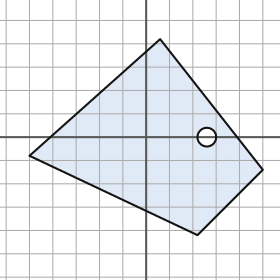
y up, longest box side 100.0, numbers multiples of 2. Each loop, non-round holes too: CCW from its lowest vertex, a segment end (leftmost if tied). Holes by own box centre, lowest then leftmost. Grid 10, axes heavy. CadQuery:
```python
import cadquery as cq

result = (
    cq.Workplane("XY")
    .moveTo(22.0, -42.0)
    .lineTo(50.0, -14.0)
    .lineTo(6.0, 42.0)
    .lineTo(-50.0, -8.0)
    .close()
    .moveTo(26.0, 0.0)
    .circle(4.0)
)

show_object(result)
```